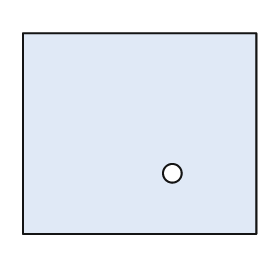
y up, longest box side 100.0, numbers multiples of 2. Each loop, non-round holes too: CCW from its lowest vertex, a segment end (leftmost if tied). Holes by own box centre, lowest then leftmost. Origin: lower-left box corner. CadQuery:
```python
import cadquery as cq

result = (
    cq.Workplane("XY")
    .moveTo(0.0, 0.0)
    .lineTo(100.0, 0.0)
    .lineTo(100.0, 86.0)
    .lineTo(0.0, 86.0)
    .close()
    .moveTo(64.0, 26.0)
    .circle(4.0)
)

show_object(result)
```